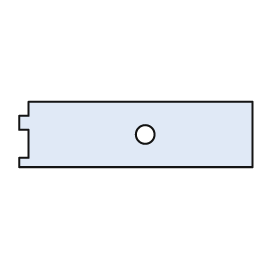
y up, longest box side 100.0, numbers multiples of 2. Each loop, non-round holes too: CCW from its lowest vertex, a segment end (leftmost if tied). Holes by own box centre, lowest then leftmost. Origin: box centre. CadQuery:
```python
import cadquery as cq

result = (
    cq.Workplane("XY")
    .moveTo(-50.0, -14.0)
    .lineTo(50.0, -14.0)
    .lineTo(50.0, 14.0)
    .lineTo(-46.0, 14.0)
    .lineTo(-46.0, 8.0)
    .lineTo(-50.0, 8.0)
    .lineTo(-50.0, 2.0)
    .lineTo(-46.0, 2.0)
    .lineTo(-46.0, -10.0)
    .lineTo(-50.0, -10.0)
    .close()
    .moveTo(4.0, 0.0)
    .circle(4.0)
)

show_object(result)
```